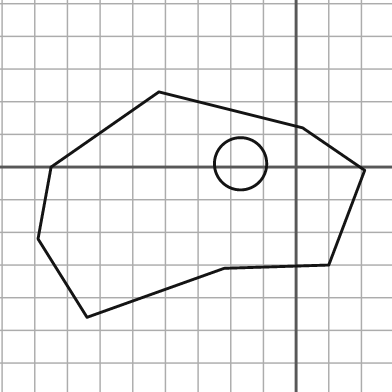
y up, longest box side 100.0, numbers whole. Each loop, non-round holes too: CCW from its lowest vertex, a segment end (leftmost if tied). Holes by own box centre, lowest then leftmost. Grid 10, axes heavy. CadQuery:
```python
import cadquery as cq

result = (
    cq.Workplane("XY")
    .moveTo(-64.0, -46.0)
    .lineTo(-22.0, -31.0)
    .lineTo(10.0, -30.0)
    .lineTo(21.0, -1.0)
    .lineTo(2.0, 12.0)
    .lineTo(-42.0, 23.0)
    .lineTo(-75.0, 0.0)
    .lineTo(-79.0, -22.0)
    .close()
    .moveTo(-17.0, 1.0)
    .circle(8.0)
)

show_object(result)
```